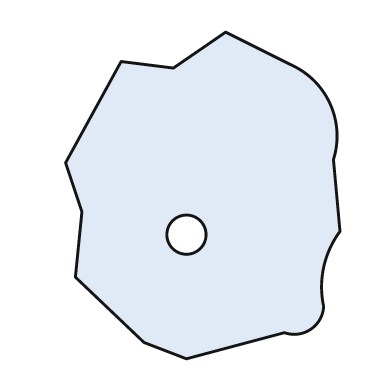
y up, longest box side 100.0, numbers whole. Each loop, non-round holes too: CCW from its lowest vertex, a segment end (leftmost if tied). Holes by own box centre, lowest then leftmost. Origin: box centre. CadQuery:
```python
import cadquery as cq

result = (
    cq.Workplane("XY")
    .moveTo(-5.0, -50.0)
    .lineTo(25.0, -42.0)
    .threePointArc((33.0, -41.0), (37.0, -34.0))
    .threePointArc((37.0, -22.0), (42.0, -11.0))
    .lineTo(40.0, 11.0)
    .threePointArc((39.0, 28.0), (27.0, 40.0))
    .lineTo(7.0, 50.0)
    .lineTo(-9.0, 39.0)
    .lineTo(-25.0, 41.0)
    .lineTo(-42.0, 10.0)
    .lineTo(-37.0, -5.0)
    .lineTo(-39.0, -25.0)
    .lineTo(-18.0, -45.0)
    .close()
    .moveTo(-5.0, -12.0)
    .circle(6.0)
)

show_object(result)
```